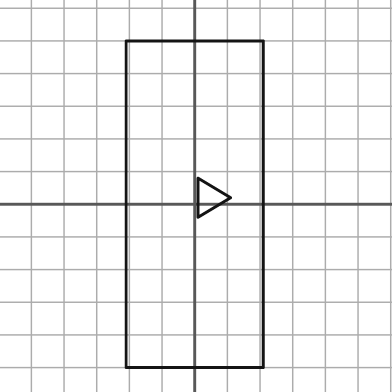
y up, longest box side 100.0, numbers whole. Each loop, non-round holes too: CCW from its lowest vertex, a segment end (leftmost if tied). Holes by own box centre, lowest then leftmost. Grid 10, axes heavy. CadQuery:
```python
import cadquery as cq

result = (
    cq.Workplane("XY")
    .moveTo(-21.0, -50.0)
    .lineTo(21.0, -50.0)
    .lineTo(21.0, 50.0)
    .lineTo(-21.0, 50.0)
    .close()
    .moveTo(1.0, -4.0)
    .lineTo(11.0, 2.0)
    .lineTo(1.0, 8.0)
    .close()
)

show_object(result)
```